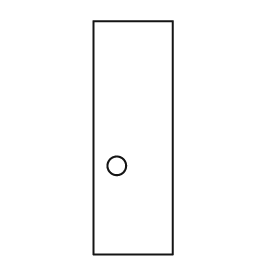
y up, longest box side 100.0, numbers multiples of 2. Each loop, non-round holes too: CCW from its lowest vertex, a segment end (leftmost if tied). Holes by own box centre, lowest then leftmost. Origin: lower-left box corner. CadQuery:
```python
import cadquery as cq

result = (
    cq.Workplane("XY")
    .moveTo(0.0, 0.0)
    .lineTo(34.0, 0.0)
    .lineTo(34.0, 100.0)
    .lineTo(0.0, 100.0)
    .close()
    .moveTo(10.0, 38.0)
    .circle(4.0)
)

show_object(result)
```